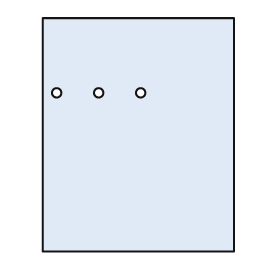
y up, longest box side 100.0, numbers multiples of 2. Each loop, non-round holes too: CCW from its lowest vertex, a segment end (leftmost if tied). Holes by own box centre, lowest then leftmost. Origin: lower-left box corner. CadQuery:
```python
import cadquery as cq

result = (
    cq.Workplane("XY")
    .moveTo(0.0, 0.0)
    .lineTo(82.0, 0.0)
    .lineTo(82.0, 100.0)
    .lineTo(0.0, 100.0)
    .close()
    .moveTo(6.0, 68.0)
    .circle(2.0)
    .moveTo(24.0, 68.0)
    .circle(2.0)
    .moveTo(42.0, 68.0)
    .circle(2.0)
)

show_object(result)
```